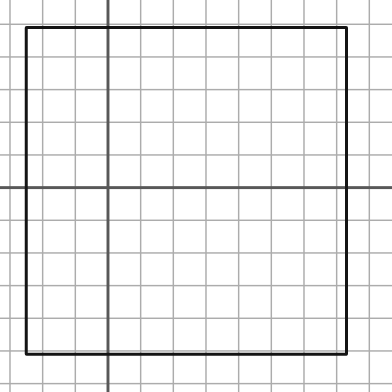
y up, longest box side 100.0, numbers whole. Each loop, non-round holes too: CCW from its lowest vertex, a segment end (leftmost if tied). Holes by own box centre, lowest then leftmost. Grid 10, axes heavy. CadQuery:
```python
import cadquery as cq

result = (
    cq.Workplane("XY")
    .moveTo(-25.0, -51.0)
    .lineTo(73.0, -51.0)
    .lineTo(73.0, 49.0)
    .lineTo(-25.0, 49.0)
    .close()
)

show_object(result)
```